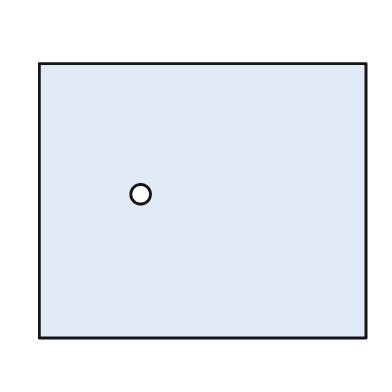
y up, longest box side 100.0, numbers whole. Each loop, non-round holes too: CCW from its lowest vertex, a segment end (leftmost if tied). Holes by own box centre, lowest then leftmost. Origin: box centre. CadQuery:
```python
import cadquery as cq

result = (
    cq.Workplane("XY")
    .moveTo(-50.0, -42.0)
    .lineTo(50.0, -42.0)
    .lineTo(50.0, 42.0)
    .lineTo(-50.0, 42.0)
    .close()
    .moveTo(-19.0, 2.0)
    .circle(3.0)
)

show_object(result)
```